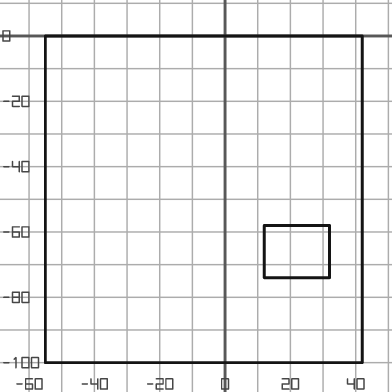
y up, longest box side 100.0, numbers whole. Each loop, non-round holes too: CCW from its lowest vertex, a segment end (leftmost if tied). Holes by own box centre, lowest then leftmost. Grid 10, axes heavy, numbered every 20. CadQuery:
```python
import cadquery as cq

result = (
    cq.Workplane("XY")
    .moveTo(-55.0, -100.0)
    .lineTo(42.0, -100.0)
    .lineTo(42.0, 0.0)
    .lineTo(-55.0, 0.0)
    .close()
    .moveTo(12.0, -74.0)
    .lineTo(32.0, -74.0)
    .lineTo(32.0, -58.0)
    .lineTo(12.0, -58.0)
    .close()
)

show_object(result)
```